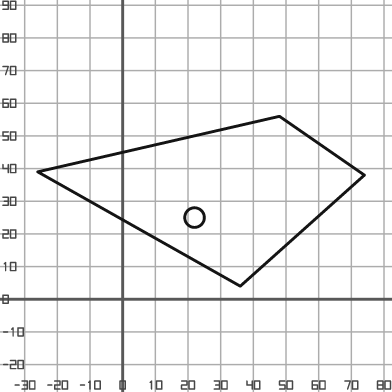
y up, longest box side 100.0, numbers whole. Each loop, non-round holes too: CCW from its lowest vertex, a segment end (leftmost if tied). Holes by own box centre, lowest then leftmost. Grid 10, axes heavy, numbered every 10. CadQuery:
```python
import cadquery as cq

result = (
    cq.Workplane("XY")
    .moveTo(36.0, 4.0)
    .lineTo(74.0, 38.0)
    .lineTo(48.0, 56.0)
    .lineTo(-26.0, 39.0)
    .close()
    .moveTo(22.0, 25.0)
    .circle(3.0)
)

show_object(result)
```